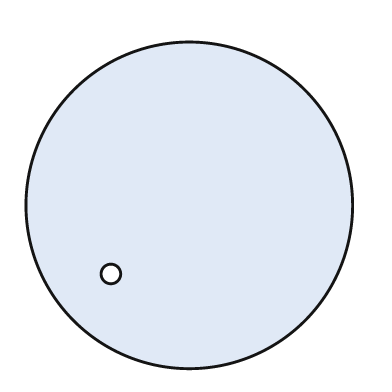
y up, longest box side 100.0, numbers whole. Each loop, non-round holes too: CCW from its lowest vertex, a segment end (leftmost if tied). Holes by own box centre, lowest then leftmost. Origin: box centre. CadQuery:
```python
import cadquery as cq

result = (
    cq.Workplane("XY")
    .moveTo(0.0, 0.0)
    .circle(50.0)
    .moveTo(-24.0, -21.0)
    .circle(3.0)
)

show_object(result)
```